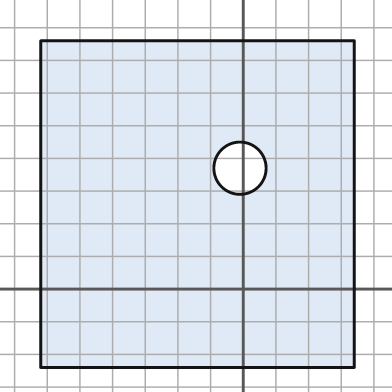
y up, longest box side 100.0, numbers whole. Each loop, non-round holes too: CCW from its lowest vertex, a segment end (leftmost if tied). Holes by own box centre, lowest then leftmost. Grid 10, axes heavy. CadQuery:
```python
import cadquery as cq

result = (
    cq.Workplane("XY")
    .moveTo(-62.0, -24.0)
    .lineTo(34.0, -24.0)
    .lineTo(34.0, 76.0)
    .lineTo(-62.0, 76.0)
    .close()
    .moveTo(-1.0, 37.0)
    .circle(8.0)
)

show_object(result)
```